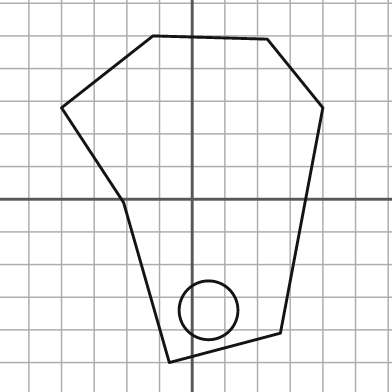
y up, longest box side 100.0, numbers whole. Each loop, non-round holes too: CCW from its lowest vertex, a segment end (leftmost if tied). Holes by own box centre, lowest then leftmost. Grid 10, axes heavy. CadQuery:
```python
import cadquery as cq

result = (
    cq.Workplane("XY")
    .moveTo(-7.0, -50.0)
    .lineTo(27.0, -41.0)
    .lineTo(40.0, 28.0)
    .lineTo(23.0, 49.0)
    .lineTo(-12.0, 50.0)
    .lineTo(-40.0, 28.0)
    .lineTo(-21.0, -1.0)
    .close()
    .moveTo(5.0, -34.0)
    .circle(9.0)
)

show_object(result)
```